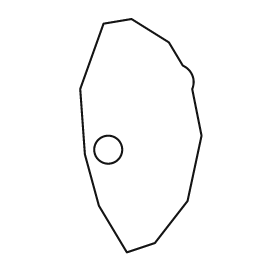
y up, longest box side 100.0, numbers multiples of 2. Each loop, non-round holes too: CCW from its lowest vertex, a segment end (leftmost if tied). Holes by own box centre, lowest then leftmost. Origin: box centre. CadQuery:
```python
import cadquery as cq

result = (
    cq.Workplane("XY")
    .moveTo(-6.0, -50.0)
    .lineTo(6.0, -46.0)
    .lineTo(20.0, -28.0)
    .lineTo(26.0, 0.0)
    .lineTo(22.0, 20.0)
    .threePointArc((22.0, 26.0), (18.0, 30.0))
    .lineTo(12.0, 40.0)
    .lineTo(-4.0, 50.0)
    .lineTo(-16.0, 48.0)
    .lineTo(-26.0, 20.0)
    .lineTo(-24.0, -8.0)
    .lineTo(-18.0, -30.0)
    .close()
    .moveTo(-14.0, -6.0)
    .circle(6.0)
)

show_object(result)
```